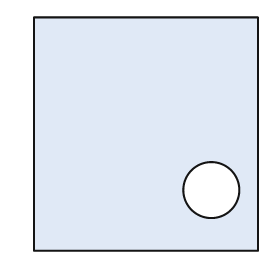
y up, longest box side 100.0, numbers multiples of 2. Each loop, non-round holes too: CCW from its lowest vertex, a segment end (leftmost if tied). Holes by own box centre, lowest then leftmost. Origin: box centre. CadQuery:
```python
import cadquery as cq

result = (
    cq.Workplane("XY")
    .moveTo(-48.0, -50.0)
    .lineTo(48.0, -50.0)
    .lineTo(48.0, 50.0)
    .lineTo(-48.0, 50.0)
    .close()
    .moveTo(28.0, -24.0)
    .circle(12.0)
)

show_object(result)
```